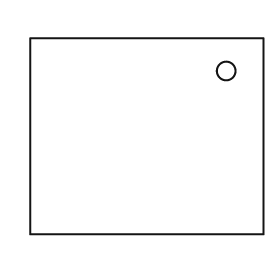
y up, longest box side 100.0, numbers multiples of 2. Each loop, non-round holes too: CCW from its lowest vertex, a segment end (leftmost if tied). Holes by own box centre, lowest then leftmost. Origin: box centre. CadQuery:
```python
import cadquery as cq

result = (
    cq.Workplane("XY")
    .moveTo(-50.0, -42.0)
    .lineTo(50.0, -42.0)
    .lineTo(50.0, 42.0)
    .lineTo(-50.0, 42.0)
    .close()
    .moveTo(34.0, 28.0)
    .circle(4.0)
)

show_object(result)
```